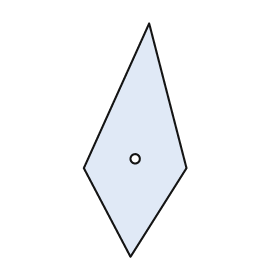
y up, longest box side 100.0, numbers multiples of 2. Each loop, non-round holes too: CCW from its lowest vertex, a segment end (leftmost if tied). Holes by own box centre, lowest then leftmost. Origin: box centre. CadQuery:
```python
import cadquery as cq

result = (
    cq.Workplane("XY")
    .moveTo(-2.0, -50.0)
    .lineTo(22.0, -12.0)
    .lineTo(6.0, 50.0)
    .lineTo(-22.0, -12.0)
    .close()
    .moveTo(0.0, -8.0)
    .circle(2.0)
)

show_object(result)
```